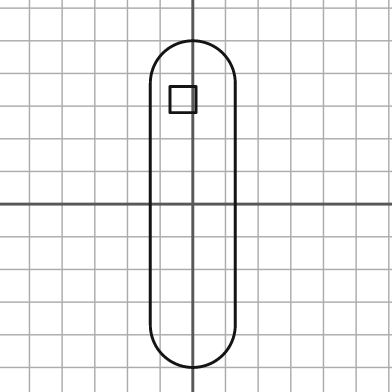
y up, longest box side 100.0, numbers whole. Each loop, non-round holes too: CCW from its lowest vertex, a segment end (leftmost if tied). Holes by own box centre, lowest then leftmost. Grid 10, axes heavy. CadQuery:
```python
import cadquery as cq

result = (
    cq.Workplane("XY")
    .moveTo(-13.0, -37.0)
    .threePointArc((0.0, -50.0), (13.0, -37.0))
    .lineTo(13.0, 37.0)
    .threePointArc((0.0, 50.0), (-13.0, 37.0))
    .close()
    .moveTo(-7.0, 28.0)
    .lineTo(1.0, 28.0)
    .lineTo(1.0, 36.0)
    .lineTo(-7.0, 36.0)
    .close()
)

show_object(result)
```